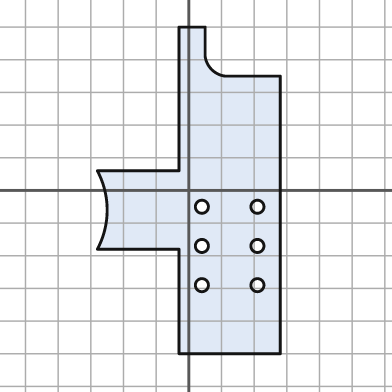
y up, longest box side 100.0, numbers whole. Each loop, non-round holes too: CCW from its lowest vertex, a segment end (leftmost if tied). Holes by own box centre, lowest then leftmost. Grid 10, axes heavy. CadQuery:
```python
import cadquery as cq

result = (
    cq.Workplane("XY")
    .moveTo(-3.0, -50.0)
    .lineTo(28.0, -50.0)
    .lineTo(28.0, 35.0)
    .lineTo(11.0, 35.0)
    .threePointArc((7.0, 37.0), (5.0, 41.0))
    .lineTo(5.0, 50.0)
    .lineTo(-3.0, 50.0)
    .lineTo(-3.0, 6.0)
    .lineTo(-28.0, 6.0)
    .threePointArc((-25.0, -6.0), (-28.0, -18.0))
    .lineTo(-3.0, -18.0)
    .close()
    .moveTo(4.0, -29.0)
    .circle(2.0)
    .moveTo(21.0, -29.0)
    .circle(2.0)
    .moveTo(4.0, -17.0)
    .circle(2.0)
    .moveTo(21.0, -17.0)
    .circle(2.0)
    .moveTo(4.0, -5.0)
    .circle(2.0)
    .moveTo(21.0, -5.0)
    .circle(2.0)
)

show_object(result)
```